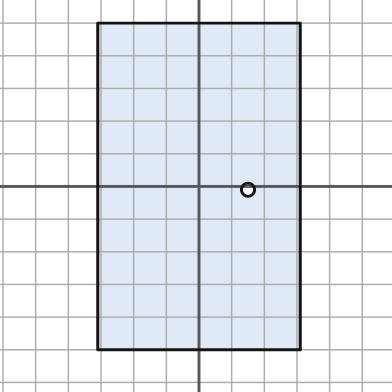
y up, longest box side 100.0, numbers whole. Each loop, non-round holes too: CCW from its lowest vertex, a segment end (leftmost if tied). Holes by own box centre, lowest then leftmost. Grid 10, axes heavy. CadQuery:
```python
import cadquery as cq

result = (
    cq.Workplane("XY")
    .moveTo(-31.0, -50.0)
    .lineTo(31.0, -50.0)
    .lineTo(31.0, 50.0)
    .lineTo(-31.0, 50.0)
    .close()
    .moveTo(15.0, -1.0)
    .circle(2.0)
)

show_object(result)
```